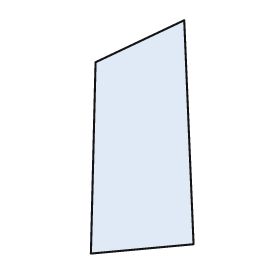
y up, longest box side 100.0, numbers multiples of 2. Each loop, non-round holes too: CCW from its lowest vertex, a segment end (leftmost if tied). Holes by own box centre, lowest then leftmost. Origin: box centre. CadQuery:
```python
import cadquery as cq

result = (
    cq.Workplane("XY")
    .moveTo(-22.0, -50.0)
    .lineTo(22.0, -46.0)
    .lineTo(18.0, 50.0)
    .lineTo(-20.0, 32.0)
    .close()
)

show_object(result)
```